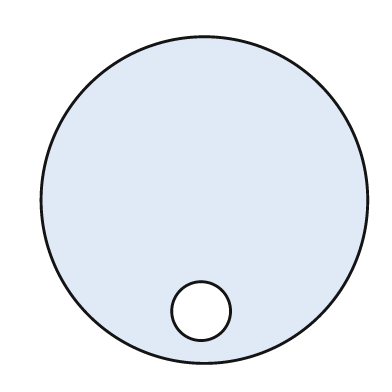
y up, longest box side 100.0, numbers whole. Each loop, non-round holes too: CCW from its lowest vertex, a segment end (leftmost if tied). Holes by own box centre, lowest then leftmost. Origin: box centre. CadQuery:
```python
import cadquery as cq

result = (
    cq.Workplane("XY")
    .moveTo(0.0, 0.0)
    .circle(50.0)
    .moveTo(-1.0, -34.0)
    .circle(9.0)
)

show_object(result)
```